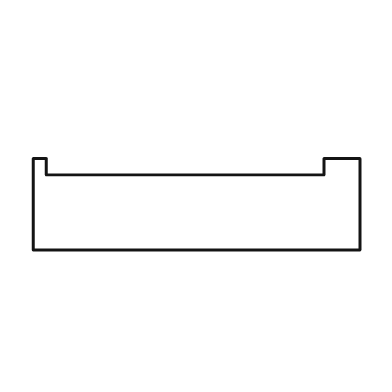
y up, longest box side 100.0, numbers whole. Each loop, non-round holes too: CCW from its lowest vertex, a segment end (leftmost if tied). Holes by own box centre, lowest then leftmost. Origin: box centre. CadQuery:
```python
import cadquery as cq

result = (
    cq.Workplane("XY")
    .moveTo(-50.0, -14.0)
    .lineTo(50.0, -14.0)
    .lineTo(50.0, 14.0)
    .lineTo(39.0, 14.0)
    .lineTo(39.0, 9.0)
    .lineTo(-46.0, 9.0)
    .lineTo(-46.0, 14.0)
    .lineTo(-50.0, 14.0)
    .close()
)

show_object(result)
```